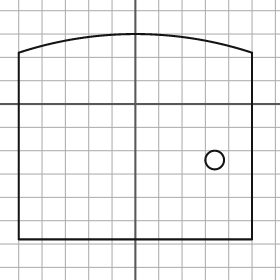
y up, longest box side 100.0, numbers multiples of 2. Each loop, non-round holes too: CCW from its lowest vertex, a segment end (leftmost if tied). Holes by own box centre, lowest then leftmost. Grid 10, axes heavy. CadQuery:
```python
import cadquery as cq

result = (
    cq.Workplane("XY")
    .moveTo(-50.0, -58.0)
    .lineTo(50.0, -58.0)
    .lineTo(50.0, 22.0)
    .threePointArc((0.0, 30.0), (-50.0, 22.0))
    .close()
    .moveTo(34.0, -24.0)
    .circle(4.0)
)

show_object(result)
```